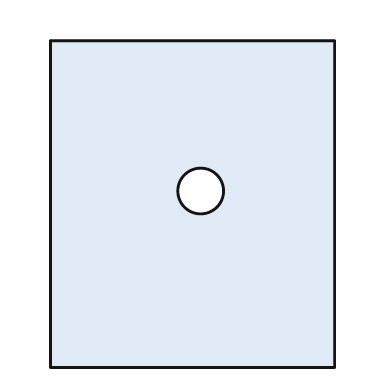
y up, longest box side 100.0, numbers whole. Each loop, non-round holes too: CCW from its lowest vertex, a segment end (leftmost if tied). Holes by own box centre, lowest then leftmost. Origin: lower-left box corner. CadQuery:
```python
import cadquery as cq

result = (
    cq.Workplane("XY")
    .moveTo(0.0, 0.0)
    .lineTo(87.0, 0.0)
    .lineTo(87.0, 100.0)
    .lineTo(0.0, 100.0)
    .close()
    .moveTo(46.0, 54.0)
    .circle(7.0)
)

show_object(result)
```